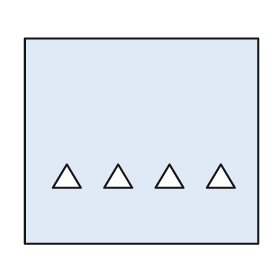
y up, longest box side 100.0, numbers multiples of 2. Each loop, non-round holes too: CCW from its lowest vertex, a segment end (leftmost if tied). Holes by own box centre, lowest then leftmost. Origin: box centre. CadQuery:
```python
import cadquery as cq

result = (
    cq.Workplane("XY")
    .moveTo(-50.0, -44.0)
    .lineTo(50.0, -44.0)
    .lineTo(50.0, 44.0)
    .lineTo(-50.0, 44.0)
    .close()
    .moveTo(-38.0, -20.0)
    .lineTo(-26.0, -20.0)
    .lineTo(-32.0, -10.0)
    .close()
    .moveTo(-16.0, -20.0)
    .lineTo(-4.0, -20.0)
    .lineTo(-10.0, -10.0)
    .close()
    .moveTo(6.0, -20.0)
    .lineTo(18.0, -20.0)
    .lineTo(12.0, -10.0)
    .close()
    .moveTo(28.0, -20.0)
    .lineTo(40.0, -20.0)
    .lineTo(34.0, -10.0)
    .close()
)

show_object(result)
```